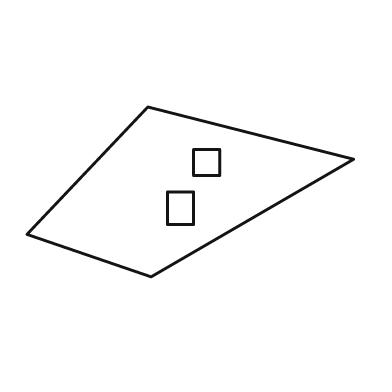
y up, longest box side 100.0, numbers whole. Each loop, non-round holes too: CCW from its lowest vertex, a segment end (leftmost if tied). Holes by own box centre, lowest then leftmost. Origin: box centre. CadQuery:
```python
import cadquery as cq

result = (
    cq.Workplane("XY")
    .moveTo(-12.0, -26.0)
    .lineTo(50.0, 10.0)
    .lineTo(-13.0, 26.0)
    .lineTo(-50.0, -13.0)
    .close()
    .moveTo(-7.0, -10.0)
    .lineTo(1.0, -10.0)
    .lineTo(1.0, 0.0)
    .lineTo(-7.0, 0.0)
    .close()
    .moveTo(1.0, 5.0)
    .lineTo(9.0, 5.0)
    .lineTo(9.0, 13.0)
    .lineTo(1.0, 13.0)
    .close()
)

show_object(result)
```